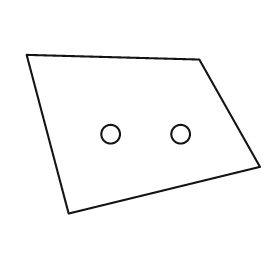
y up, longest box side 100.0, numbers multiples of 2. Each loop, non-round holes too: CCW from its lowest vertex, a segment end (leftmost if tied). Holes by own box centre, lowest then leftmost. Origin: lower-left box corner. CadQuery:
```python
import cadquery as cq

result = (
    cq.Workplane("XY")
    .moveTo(18.0, 0.0)
    .lineTo(100.0, 20.0)
    .lineTo(74.0, 66.0)
    .lineTo(0.0, 68.0)
    .close()
    .moveTo(36.0, 34.0)
    .circle(4.0)
    .moveTo(66.0, 34.0)
    .circle(4.0)
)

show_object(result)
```